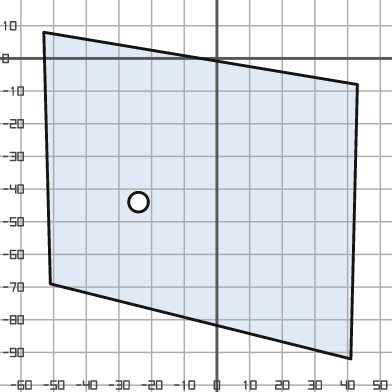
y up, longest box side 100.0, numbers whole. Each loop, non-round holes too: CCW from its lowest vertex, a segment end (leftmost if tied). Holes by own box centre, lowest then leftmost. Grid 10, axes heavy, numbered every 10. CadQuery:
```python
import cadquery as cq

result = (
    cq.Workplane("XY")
    .moveTo(41.0, -92.0)
    .lineTo(43.0, -8.0)
    .lineTo(-53.0, 8.0)
    .lineTo(-51.0, -69.0)
    .close()
    .moveTo(-24.0, -44.0)
    .circle(3.0)
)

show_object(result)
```